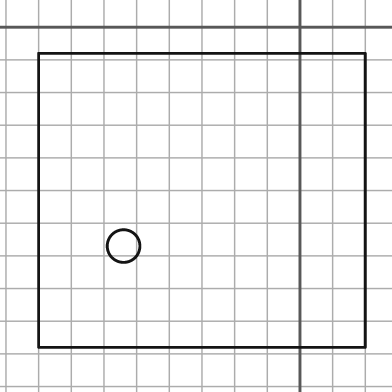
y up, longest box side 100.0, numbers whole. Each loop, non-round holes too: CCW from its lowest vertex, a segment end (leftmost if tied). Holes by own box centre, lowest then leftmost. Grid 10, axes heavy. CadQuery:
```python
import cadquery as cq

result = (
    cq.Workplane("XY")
    .moveTo(-80.0, -98.0)
    .lineTo(20.0, -98.0)
    .lineTo(20.0, -8.0)
    .lineTo(-80.0, -8.0)
    .close()
    .moveTo(-54.0, -67.0)
    .circle(5.0)
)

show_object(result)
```